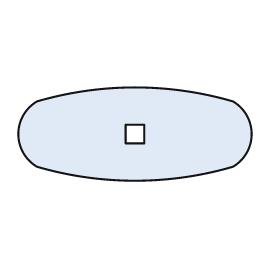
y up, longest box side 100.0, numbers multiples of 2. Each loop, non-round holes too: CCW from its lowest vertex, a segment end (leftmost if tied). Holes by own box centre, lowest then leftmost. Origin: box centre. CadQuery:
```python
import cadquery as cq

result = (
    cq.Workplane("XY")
    .moveTo(-42.0, -14.0)
    .threePointArc((0.0, -20.0), (42.0, -14.0))
    .threePointArc((50.0, 0.0), (42.0, 14.0))
    .threePointArc((0.0, 20.0), (-42.0, 14.0))
    .threePointArc((-50.0, 0.0), (-42.0, -14.0))
    .close()
    .moveTo(-4.0, -4.0)
    .lineTo(4.0, -4.0)
    .lineTo(4.0, 4.0)
    .lineTo(-4.0, 4.0)
    .close()
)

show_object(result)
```